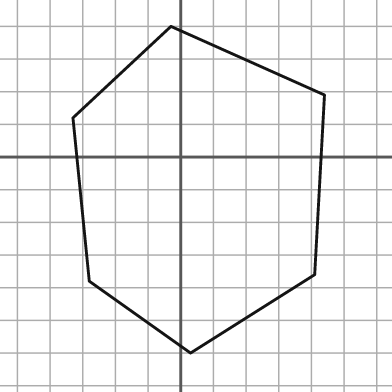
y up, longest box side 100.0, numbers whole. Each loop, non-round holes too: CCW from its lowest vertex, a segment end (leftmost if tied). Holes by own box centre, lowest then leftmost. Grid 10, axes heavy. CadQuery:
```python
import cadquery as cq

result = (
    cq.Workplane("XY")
    .moveTo(3.0, -60.0)
    .lineTo(41.0, -36.0)
    .lineTo(44.0, 19.0)
    .lineTo(-3.0, 40.0)
    .lineTo(-33.0, 12.0)
    .lineTo(-28.0, -38.0)
    .close()
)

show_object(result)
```